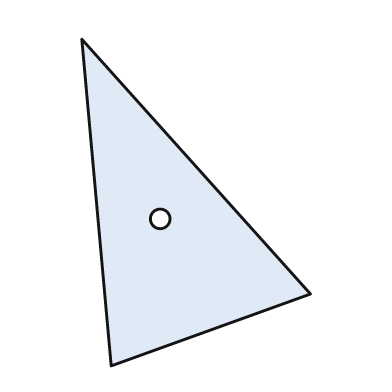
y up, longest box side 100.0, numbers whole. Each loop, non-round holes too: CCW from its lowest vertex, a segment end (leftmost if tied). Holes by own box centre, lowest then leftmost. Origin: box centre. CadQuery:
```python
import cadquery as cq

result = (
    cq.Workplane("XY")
    .moveTo(-26.0, -50.0)
    .lineTo(35.0, -28.0)
    .lineTo(-35.0, 50.0)
    .close()
    .moveTo(-11.0, -5.0)
    .circle(3.0)
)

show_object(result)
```